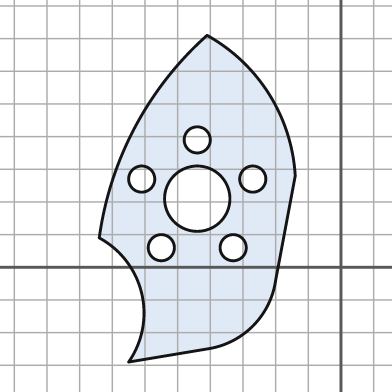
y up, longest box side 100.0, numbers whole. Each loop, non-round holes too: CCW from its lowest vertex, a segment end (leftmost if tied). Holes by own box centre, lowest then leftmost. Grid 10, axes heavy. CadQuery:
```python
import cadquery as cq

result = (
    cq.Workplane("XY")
    .moveTo(-65.0, -29.0)
    .lineTo(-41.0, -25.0)
    .threePointArc((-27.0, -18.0), (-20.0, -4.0))
    .lineTo(-14.0, 28.0)
    .threePointArc((-22.0, 53.0), (-41.0, 71.0))
    .threePointArc((-63.0, 43.0), (-74.0, 9.0))
    .threePointArc((-61.0, -8.0), (-65.0, -29.0))
    .close()
    .moveTo(-55.0, 6.0)
    .circle(4.0)
    .moveTo(-33.0, 6.0)
    .circle(4.0)
    .moveTo(-44.0, 21.0)
    .circle(10.0)
    .moveTo(-61.0, 27.0)
    .circle(4.0)
    .moveTo(-27.0, 27.0)
    .circle(4.0)
    .moveTo(-44.0, 39.0)
    .circle(4.0)
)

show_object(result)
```